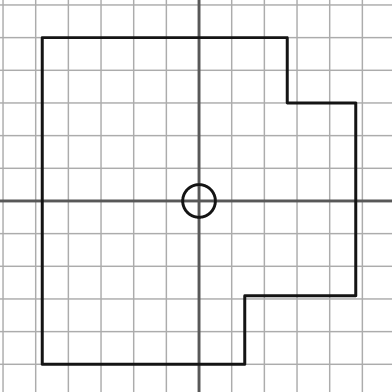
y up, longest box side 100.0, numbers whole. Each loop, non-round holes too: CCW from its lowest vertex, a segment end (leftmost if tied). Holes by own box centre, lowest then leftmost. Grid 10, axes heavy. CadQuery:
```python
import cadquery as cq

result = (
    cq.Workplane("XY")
    .moveTo(-48.0, -50.0)
    .lineTo(14.0, -50.0)
    .lineTo(14.0, -29.0)
    .lineTo(48.0, -29.0)
    .lineTo(48.0, 30.0)
    .lineTo(27.0, 30.0)
    .lineTo(27.0, 50.0)
    .lineTo(-48.0, 50.0)
    .close()
    .moveTo(0.0, 0.0)
    .circle(5.0)
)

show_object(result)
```